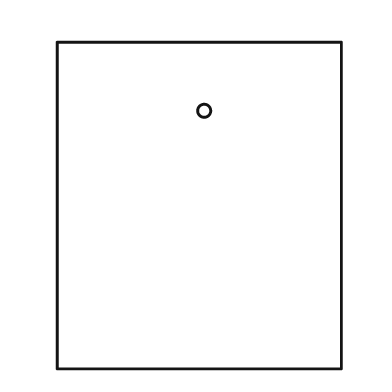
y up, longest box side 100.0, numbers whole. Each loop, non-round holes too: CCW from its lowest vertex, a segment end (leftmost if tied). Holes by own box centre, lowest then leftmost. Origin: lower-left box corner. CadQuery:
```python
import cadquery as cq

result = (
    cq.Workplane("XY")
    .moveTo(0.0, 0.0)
    .lineTo(87.0, 0.0)
    .lineTo(87.0, 100.0)
    .lineTo(0.0, 100.0)
    .close()
    .moveTo(45.0, 79.0)
    .circle(2.0)
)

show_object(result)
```